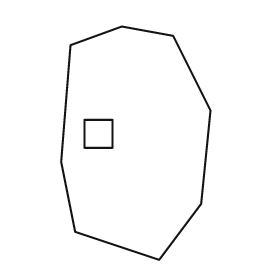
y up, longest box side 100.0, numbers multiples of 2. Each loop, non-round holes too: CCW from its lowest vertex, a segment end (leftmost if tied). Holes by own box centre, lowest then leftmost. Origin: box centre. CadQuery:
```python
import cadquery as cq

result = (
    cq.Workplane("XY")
    .moveTo(10.0, -50.0)
    .lineTo(28.0, -26.0)
    .lineTo(32.0, 14.0)
    .lineTo(16.0, 46.0)
    .lineTo(-6.0, 50.0)
    .lineTo(-28.0, 42.0)
    .lineTo(-32.0, -8.0)
    .lineTo(-26.0, -38.0)
    .close()
    .moveTo(-22.0, -2.0)
    .lineTo(-10.0, -2.0)
    .lineTo(-10.0, 10.0)
    .lineTo(-22.0, 10.0)
    .close()
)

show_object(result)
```